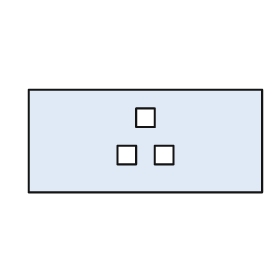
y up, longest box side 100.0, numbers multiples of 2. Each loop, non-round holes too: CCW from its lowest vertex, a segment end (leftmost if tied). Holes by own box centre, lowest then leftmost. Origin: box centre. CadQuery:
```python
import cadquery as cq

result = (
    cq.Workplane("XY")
    .moveTo(-50.0, -22.0)
    .lineTo(50.0, -22.0)
    .lineTo(50.0, 22.0)
    .lineTo(-50.0, 22.0)
    .close()
    .moveTo(-12.0, -10.0)
    .lineTo(-4.0, -10.0)
    .lineTo(-4.0, -2.0)
    .lineTo(-12.0, -2.0)
    .close()
    .moveTo(4.0, -10.0)
    .lineTo(12.0, -10.0)
    .lineTo(12.0, -2.0)
    .lineTo(4.0, -2.0)
    .close()
    .moveTo(-4.0, 6.0)
    .lineTo(4.0, 6.0)
    .lineTo(4.0, 14.0)
    .lineTo(-4.0, 14.0)
    .close()
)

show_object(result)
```